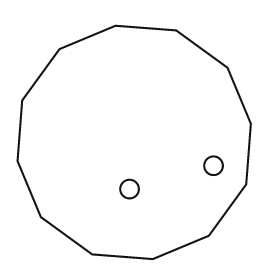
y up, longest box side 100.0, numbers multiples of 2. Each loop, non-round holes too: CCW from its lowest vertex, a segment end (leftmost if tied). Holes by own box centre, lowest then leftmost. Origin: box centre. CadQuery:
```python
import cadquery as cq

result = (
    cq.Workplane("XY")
    .moveTo(8.0, -50.0)
    .lineTo(32.0, -40.0)
    .lineTo(48.0, -18.0)
    .lineTo(50.0, 8.0)
    .lineTo(40.0, 32.0)
    .lineTo(18.0, 48.0)
    .lineTo(-8.0, 50.0)
    .lineTo(-32.0, 40.0)
    .lineTo(-48.0, 18.0)
    .lineTo(-50.0, -8.0)
    .lineTo(-40.0, -32.0)
    .lineTo(-18.0, -48.0)
    .close()
    .moveTo(-2.0, -20.0)
    .circle(4.0)
    .moveTo(34.0, -10.0)
    .circle(4.0)
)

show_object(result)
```